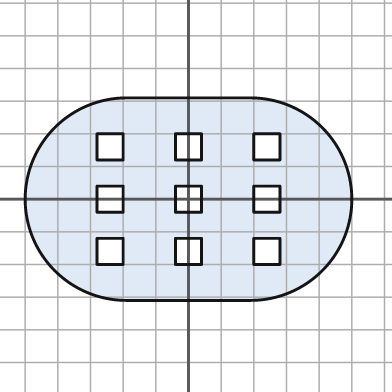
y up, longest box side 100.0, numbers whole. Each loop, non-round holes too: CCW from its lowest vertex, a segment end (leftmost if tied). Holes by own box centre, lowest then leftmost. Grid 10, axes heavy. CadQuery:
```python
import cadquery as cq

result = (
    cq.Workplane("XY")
    .moveTo(-19.0, -31.0)
    .lineTo(19.0, -31.0)
    .threePointArc((50.0, 0.0), (19.0, 31.0))
    .lineTo(-19.0, 31.0)
    .threePointArc((-50.0, 0.0), (-19.0, -31.0))
    .close()
    .moveTo(-28.0, -20.0)
    .lineTo(-20.0, -20.0)
    .lineTo(-20.0, -12.0)
    .lineTo(-28.0, -12.0)
    .close()
    .moveTo(-4.0, -20.0)
    .lineTo(4.0, -20.0)
    .lineTo(4.0, -12.0)
    .lineTo(-4.0, -12.0)
    .close()
    .moveTo(20.0, -20.0)
    .lineTo(28.0, -20.0)
    .lineTo(28.0, -12.0)
    .lineTo(20.0, -12.0)
    .close()
    .moveTo(-28.0, -4.0)
    .lineTo(-20.0, -4.0)
    .lineTo(-20.0, 4.0)
    .lineTo(-28.0, 4.0)
    .close()
    .moveTo(-4.0, -4.0)
    .lineTo(4.0, -4.0)
    .lineTo(4.0, 4.0)
    .lineTo(-4.0, 4.0)
    .close()
    .moveTo(20.0, -4.0)
    .lineTo(28.0, -4.0)
    .lineTo(28.0, 4.0)
    .lineTo(20.0, 4.0)
    .close()
    .moveTo(-28.0, 12.0)
    .lineTo(-20.0, 12.0)
    .lineTo(-20.0, 20.0)
    .lineTo(-28.0, 20.0)
    .close()
    .moveTo(-4.0, 12.0)
    .lineTo(4.0, 12.0)
    .lineTo(4.0, 20.0)
    .lineTo(-4.0, 20.0)
    .close()
    .moveTo(20.0, 12.0)
    .lineTo(28.0, 12.0)
    .lineTo(28.0, 20.0)
    .lineTo(20.0, 20.0)
    .close()
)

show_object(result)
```